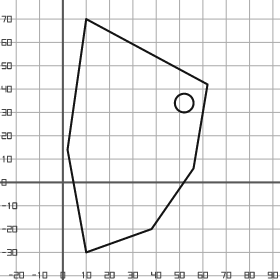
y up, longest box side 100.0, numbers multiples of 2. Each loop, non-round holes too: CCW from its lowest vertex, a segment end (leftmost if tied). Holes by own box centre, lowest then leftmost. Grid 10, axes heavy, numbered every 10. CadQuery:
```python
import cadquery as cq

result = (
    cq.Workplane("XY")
    .moveTo(10.0, -30.0)
    .lineTo(38.0, -20.0)
    .lineTo(56.0, 6.0)
    .lineTo(62.0, 42.0)
    .lineTo(10.0, 70.0)
    .lineTo(2.0, 14.0)
    .close()
    .moveTo(52.0, 34.0)
    .circle(4.0)
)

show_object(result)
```